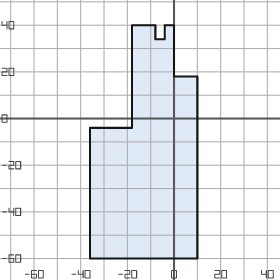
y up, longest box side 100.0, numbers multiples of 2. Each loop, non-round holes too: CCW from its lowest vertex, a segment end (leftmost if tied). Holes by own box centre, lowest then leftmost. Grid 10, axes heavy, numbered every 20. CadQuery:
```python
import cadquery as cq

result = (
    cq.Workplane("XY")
    .moveTo(-36.0, -60.0)
    .lineTo(10.0, -60.0)
    .lineTo(10.0, 18.0)
    .lineTo(0.0, 18.0)
    .lineTo(0.0, 40.0)
    .lineTo(-4.0, 40.0)
    .lineTo(-4.0, 34.0)
    .lineTo(-8.0, 34.0)
    .lineTo(-8.0, 40.0)
    .lineTo(-18.0, 40.0)
    .lineTo(-18.0, -4.0)
    .lineTo(-36.0, -4.0)
    .close()
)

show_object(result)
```